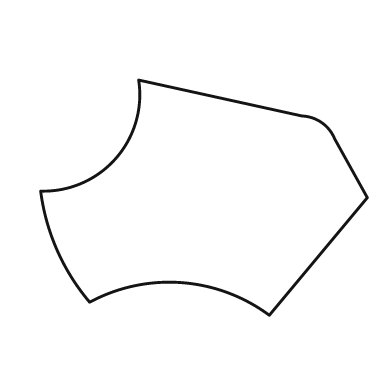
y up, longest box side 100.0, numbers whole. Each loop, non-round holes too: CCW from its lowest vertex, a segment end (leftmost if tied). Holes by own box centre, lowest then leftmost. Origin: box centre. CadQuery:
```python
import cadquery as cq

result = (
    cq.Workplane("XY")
    .moveTo(20.0, -36.0)
    .lineTo(50.0, 0.0)
    .lineTo(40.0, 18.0)
    .threePointArc((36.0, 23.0), (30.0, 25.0))
    .lineTo(-20.0, 36.0)
    .threePointArc((-27.0, 12.0), (-50.0, 2.0))
    .threePointArc((-45.0, -16.0), (-35.0, -32.0))
    .threePointArc((-7.0, -26.0), (20.0, -36.0))
    .close()
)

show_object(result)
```